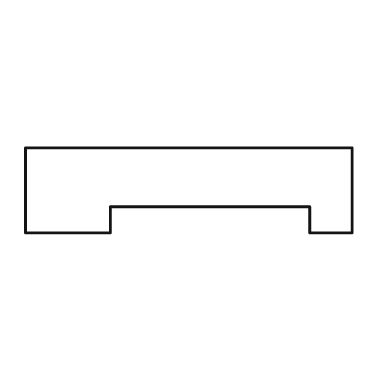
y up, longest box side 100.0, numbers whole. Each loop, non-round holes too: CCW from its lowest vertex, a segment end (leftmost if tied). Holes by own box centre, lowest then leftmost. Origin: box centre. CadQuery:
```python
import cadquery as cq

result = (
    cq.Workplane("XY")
    .moveTo(-50.0, -13.0)
    .lineTo(-24.0, -13.0)
    .lineTo(-24.0, -5.0)
    .lineTo(37.0, -5.0)
    .lineTo(37.0, -13.0)
    .lineTo(50.0, -13.0)
    .lineTo(50.0, 13.0)
    .lineTo(-50.0, 13.0)
    .close()
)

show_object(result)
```